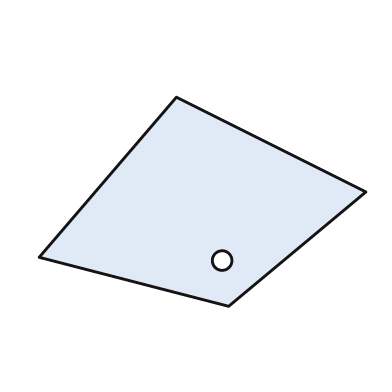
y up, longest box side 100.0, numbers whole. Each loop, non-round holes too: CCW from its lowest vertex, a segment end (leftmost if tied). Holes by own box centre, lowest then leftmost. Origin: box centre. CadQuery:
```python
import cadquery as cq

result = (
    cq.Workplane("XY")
    .moveTo(8.0, -32.0)
    .lineTo(50.0, 3.0)
    .lineTo(-8.0, 32.0)
    .lineTo(-50.0, -17.0)
    .close()
    .moveTo(6.0, -18.0)
    .circle(3.0)
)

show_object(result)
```